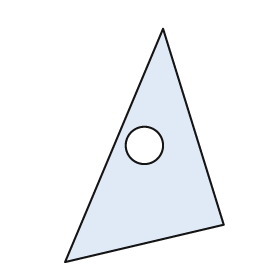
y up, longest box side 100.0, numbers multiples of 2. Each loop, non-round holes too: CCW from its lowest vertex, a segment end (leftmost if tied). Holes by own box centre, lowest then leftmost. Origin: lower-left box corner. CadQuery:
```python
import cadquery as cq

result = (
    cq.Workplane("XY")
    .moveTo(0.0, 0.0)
    .lineTo(68.0, 16.0)
    .lineTo(42.0, 100.0)
    .close()
    .moveTo(34.0, 50.0)
    .circle(8.0)
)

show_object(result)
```